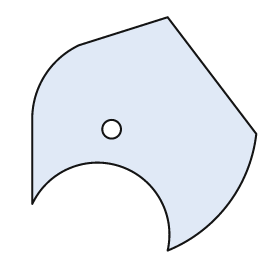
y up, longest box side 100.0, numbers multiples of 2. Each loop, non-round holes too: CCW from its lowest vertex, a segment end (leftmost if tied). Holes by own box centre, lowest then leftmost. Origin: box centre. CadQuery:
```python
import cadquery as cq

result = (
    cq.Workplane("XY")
    .moveTo(10.0, -50.0)
    .threePointArc((36.0, -30.0), (48.0, 0.0))
    .lineTo(10.0, 50.0)
    .lineTo(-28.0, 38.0)
    .threePointArc((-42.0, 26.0), (-48.0, 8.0))
    .lineTo(-48.0, -30.0)
    .threePointArc((-10.0, -14.0), (10.0, -50.0))
    .close()
    .moveTo(-14.0, 2.0)
    .circle(4.0)
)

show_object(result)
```